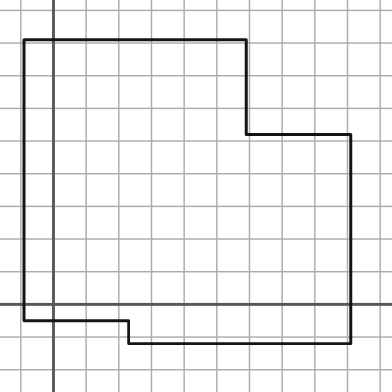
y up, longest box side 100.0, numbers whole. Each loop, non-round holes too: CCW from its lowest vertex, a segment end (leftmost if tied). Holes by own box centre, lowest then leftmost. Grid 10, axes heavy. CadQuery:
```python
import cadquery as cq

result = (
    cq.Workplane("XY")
    .moveTo(23.0, -12.0)
    .lineTo(91.0, -12.0)
    .lineTo(91.0, 52.0)
    .lineTo(59.0, 52.0)
    .lineTo(59.0, 81.0)
    .lineTo(-9.0, 81.0)
    .lineTo(-9.0, -5.0)
    .lineTo(23.0, -5.0)
    .close()
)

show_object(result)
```